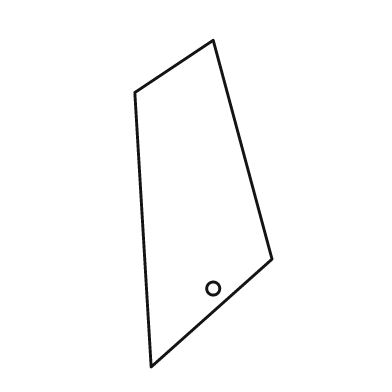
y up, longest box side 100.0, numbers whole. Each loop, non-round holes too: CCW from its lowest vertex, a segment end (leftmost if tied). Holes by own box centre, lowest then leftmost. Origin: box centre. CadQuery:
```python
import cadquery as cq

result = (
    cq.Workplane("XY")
    .moveTo(-16.0, -50.0)
    .lineTo(21.0, -17.0)
    .lineTo(3.0, 50.0)
    .lineTo(-21.0, 34.0)
    .close()
    .moveTo(3.0, -26.0)
    .circle(2.0)
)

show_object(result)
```